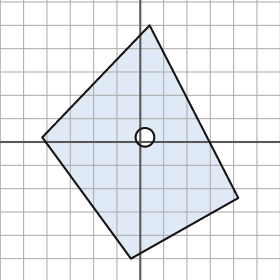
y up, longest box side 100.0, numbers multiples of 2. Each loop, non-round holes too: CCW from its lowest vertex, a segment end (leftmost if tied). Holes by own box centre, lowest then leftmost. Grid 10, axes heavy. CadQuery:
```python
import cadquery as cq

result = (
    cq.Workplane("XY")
    .moveTo(-4.0, -50.0)
    .lineTo(42.0, -24.0)
    .lineTo(4.0, 50.0)
    .lineTo(-42.0, 2.0)
    .close()
    .moveTo(2.0, 2.0)
    .circle(4.0)
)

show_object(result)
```